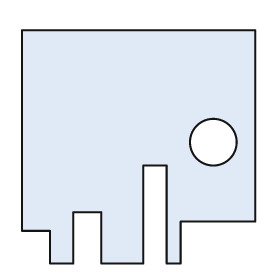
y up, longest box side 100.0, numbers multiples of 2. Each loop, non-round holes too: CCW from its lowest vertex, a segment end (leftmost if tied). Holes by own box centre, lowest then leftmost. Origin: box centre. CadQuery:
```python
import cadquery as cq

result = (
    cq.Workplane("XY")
    .moveTo(-38.0, -50.0)
    .lineTo(-28.0, -50.0)
    .lineTo(-28.0, -28.0)
    .lineTo(-16.0, -28.0)
    .lineTo(-16.0, -50.0)
    .lineTo(2.0, -50.0)
    .lineTo(2.0, -8.0)
    .lineTo(12.0, -8.0)
    .lineTo(12.0, -50.0)
    .lineTo(18.0, -50.0)
    .lineTo(18.0, -32.0)
    .lineTo(50.0, -32.0)
    .lineTo(50.0, 50.0)
    .lineTo(-50.0, 50.0)
    .lineTo(-50.0, -36.0)
    .lineTo(-38.0, -36.0)
    .close()
    .moveTo(32.0, 2.0)
    .circle(10.0)
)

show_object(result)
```